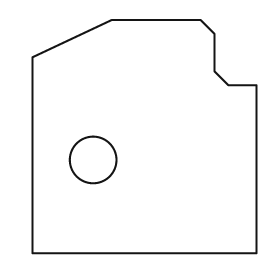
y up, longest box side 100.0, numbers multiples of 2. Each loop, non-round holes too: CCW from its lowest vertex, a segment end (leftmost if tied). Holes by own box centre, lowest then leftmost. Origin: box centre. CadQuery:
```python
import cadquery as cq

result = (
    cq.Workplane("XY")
    .moveTo(-48.0, -50.0)
    .lineTo(48.0, -50.0)
    .lineTo(48.0, 22.0)
    .lineTo(36.0, 22.0)
    .lineTo(30.0, 28.0)
    .lineTo(30.0, 44.0)
    .lineTo(24.0, 50.0)
    .lineTo(-14.0, 50.0)
    .lineTo(-48.0, 34.0)
    .close()
    .moveTo(-22.0, -10.0)
    .circle(10.0)
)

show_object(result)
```